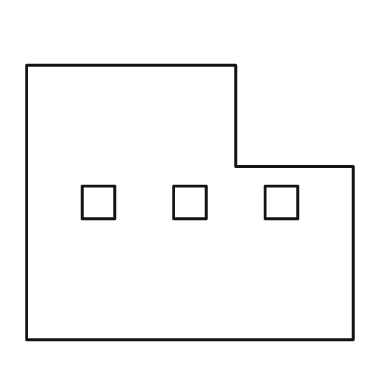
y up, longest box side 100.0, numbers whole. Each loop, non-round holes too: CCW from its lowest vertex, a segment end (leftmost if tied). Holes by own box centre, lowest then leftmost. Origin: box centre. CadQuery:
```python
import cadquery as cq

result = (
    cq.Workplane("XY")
    .moveTo(-50.0, -42.0)
    .lineTo(50.0, -42.0)
    .lineTo(50.0, 11.0)
    .lineTo(14.0, 11.0)
    .lineTo(14.0, 42.0)
    .lineTo(-50.0, 42.0)
    .close()
    .moveTo(-33.0, -5.0)
    .lineTo(-23.0, -5.0)
    .lineTo(-23.0, 5.0)
    .lineTo(-33.0, 5.0)
    .close()
    .moveTo(-5.0, -5.0)
    .lineTo(5.0, -5.0)
    .lineTo(5.0, 5.0)
    .lineTo(-5.0, 5.0)
    .close()
    .moveTo(23.0, -5.0)
    .lineTo(33.0, -5.0)
    .lineTo(33.0, 5.0)
    .lineTo(23.0, 5.0)
    .close()
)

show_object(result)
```